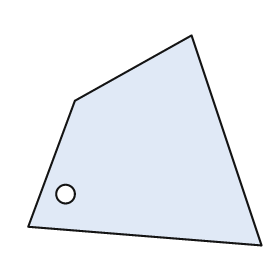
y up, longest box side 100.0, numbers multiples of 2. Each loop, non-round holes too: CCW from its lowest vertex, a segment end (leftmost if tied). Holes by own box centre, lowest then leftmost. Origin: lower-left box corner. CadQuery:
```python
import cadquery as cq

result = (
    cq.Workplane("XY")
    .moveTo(100.0, 0.0)
    .lineTo(70.0, 90.0)
    .lineTo(20.0, 62.0)
    .lineTo(0.0, 8.0)
    .close()
    .moveTo(16.0, 22.0)
    .circle(4.0)
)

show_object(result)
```